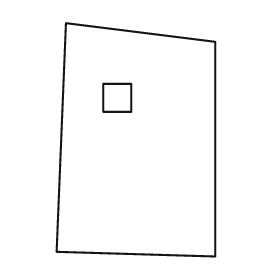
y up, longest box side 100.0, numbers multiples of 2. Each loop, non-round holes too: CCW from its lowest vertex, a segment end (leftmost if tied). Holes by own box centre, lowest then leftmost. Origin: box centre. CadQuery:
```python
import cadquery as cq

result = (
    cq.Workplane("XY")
    .moveTo(34.0, -50.0)
    .lineTo(34.0, 42.0)
    .lineTo(-30.0, 50.0)
    .lineTo(-34.0, -48.0)
    .close()
    .moveTo(-14.0, 12.0)
    .lineTo(-2.0, 12.0)
    .lineTo(-2.0, 24.0)
    .lineTo(-14.0, 24.0)
    .close()
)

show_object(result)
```